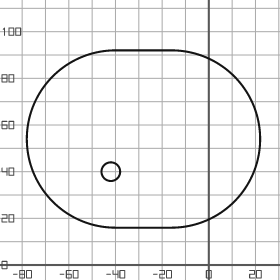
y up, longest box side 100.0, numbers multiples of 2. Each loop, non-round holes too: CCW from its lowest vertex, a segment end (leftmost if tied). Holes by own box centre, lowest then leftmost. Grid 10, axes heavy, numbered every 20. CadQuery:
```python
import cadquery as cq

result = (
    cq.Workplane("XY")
    .moveTo(-40.0, 16.0)
    .lineTo(-16.0, 16.0)
    .threePointArc((22.0, 54.0), (-16.0, 92.0))
    .lineTo(-40.0, 92.0)
    .threePointArc((-78.0, 54.0), (-40.0, 16.0))
    .close()
    .moveTo(-42.0, 40.0)
    .circle(4.0)
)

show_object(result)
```